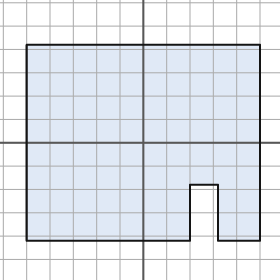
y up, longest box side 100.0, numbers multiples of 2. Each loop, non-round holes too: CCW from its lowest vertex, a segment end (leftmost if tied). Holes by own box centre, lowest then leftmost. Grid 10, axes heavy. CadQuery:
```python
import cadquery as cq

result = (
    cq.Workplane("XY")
    .moveTo(-50.0, -42.0)
    .lineTo(20.0, -42.0)
    .lineTo(20.0, -18.0)
    .lineTo(32.0, -18.0)
    .lineTo(32.0, -42.0)
    .lineTo(50.0, -42.0)
    .lineTo(50.0, 42.0)
    .lineTo(-50.0, 42.0)
    .close()
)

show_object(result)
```